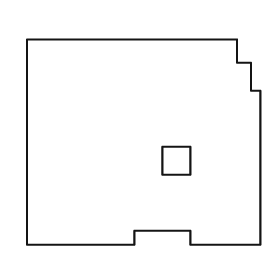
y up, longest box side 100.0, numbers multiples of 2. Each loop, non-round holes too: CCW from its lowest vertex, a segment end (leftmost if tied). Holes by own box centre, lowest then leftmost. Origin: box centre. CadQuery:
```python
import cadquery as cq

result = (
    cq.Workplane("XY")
    .moveTo(-50.0, -44.0)
    .lineTo(-4.0, -44.0)
    .lineTo(-4.0, -38.0)
    .lineTo(20.0, -38.0)
    .lineTo(20.0, -44.0)
    .lineTo(50.0, -44.0)
    .lineTo(50.0, 22.0)
    .lineTo(46.0, 22.0)
    .lineTo(46.0, 34.0)
    .lineTo(40.0, 34.0)
    .lineTo(40.0, 44.0)
    .lineTo(-50.0, 44.0)
    .close()
    .moveTo(8.0, -14.0)
    .lineTo(20.0, -14.0)
    .lineTo(20.0, -2.0)
    .lineTo(8.0, -2.0)
    .close()
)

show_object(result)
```